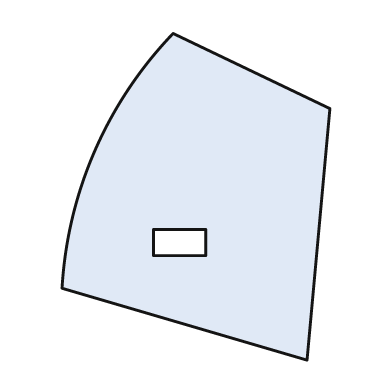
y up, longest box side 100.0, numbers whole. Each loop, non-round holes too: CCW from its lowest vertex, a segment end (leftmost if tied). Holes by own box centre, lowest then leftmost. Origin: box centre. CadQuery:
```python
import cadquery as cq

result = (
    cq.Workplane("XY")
    .moveTo(34.0, -50.0)
    .lineTo(41.0, 27.0)
    .lineTo(-7.0, 50.0)
    .threePointArc((-31.0, 14.0), (-41.0, -28.0))
    .close()
    .moveTo(-13.0, -18.0)
    .lineTo(3.0, -18.0)
    .lineTo(3.0, -10.0)
    .lineTo(-13.0, -10.0)
    .close()
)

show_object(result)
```